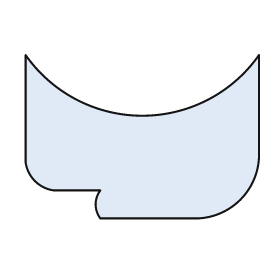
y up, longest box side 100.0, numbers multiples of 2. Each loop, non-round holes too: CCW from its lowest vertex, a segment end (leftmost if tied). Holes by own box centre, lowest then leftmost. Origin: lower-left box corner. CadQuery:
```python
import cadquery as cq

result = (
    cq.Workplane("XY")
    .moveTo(32.0, 0.0)
    .lineTo(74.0, 0.0)
    .threePointArc((92.0, 8.0), (100.0, 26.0))
    .lineTo(100.0, 70.0)
    .threePointArc((50.0, 44.0), (0.0, 70.0))
    .lineTo(0.0, 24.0)
    .threePointArc((4.0, 16.0), (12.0, 12.0))
    .lineTo(32.0, 12.0)
    .threePointArc((30.0, 6.0), (32.0, 0.0))
    .close()
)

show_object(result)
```